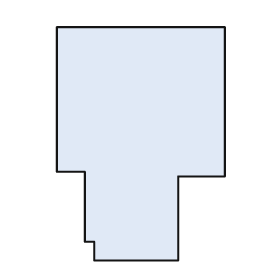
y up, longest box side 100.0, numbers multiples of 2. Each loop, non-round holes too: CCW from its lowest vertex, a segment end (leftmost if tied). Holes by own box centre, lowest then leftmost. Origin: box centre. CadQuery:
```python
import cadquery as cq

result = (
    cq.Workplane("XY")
    .moveTo(-20.0, -50.0)
    .lineTo(16.0, -50.0)
    .lineTo(16.0, -14.0)
    .lineTo(36.0, -14.0)
    .lineTo(36.0, 50.0)
    .lineTo(-36.0, 50.0)
    .lineTo(-36.0, -12.0)
    .lineTo(-24.0, -12.0)
    .lineTo(-24.0, -42.0)
    .lineTo(-20.0, -42.0)
    .close()
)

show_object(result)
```